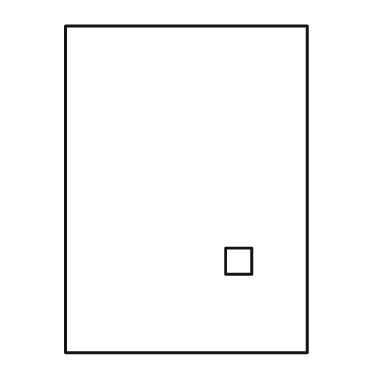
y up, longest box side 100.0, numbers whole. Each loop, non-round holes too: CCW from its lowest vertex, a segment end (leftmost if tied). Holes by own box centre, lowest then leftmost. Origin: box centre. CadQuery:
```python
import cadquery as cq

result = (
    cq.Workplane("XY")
    .moveTo(-37.0, -50.0)
    .lineTo(37.0, -50.0)
    .lineTo(37.0, 50.0)
    .lineTo(-37.0, 50.0)
    .close()
    .moveTo(12.0, -26.0)
    .lineTo(20.0, -26.0)
    .lineTo(20.0, -18.0)
    .lineTo(12.0, -18.0)
    .close()
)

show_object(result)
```